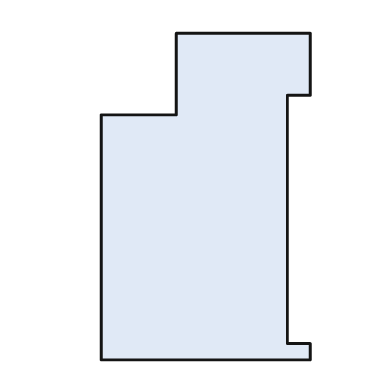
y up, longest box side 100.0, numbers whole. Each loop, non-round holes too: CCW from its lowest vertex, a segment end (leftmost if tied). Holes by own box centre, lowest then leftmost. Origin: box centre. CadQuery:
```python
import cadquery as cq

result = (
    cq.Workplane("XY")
    .moveTo(-32.0, -50.0)
    .lineTo(32.0, -50.0)
    .lineTo(32.0, -45.0)
    .lineTo(25.0, -45.0)
    .lineTo(25.0, 31.0)
    .lineTo(32.0, 31.0)
    .lineTo(32.0, 50.0)
    .lineTo(-9.0, 50.0)
    .lineTo(-9.0, 25.0)
    .lineTo(-32.0, 25.0)
    .close()
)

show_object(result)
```